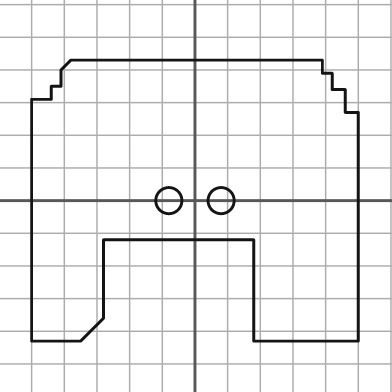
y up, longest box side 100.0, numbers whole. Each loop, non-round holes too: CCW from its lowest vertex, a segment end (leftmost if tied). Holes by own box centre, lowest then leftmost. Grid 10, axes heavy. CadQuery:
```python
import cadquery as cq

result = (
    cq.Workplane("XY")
    .moveTo(-50.0, -43.0)
    .lineTo(-35.0, -43.0)
    .lineTo(-28.0, -36.0)
    .lineTo(-28.0, -12.0)
    .lineTo(18.0, -12.0)
    .lineTo(18.0, -43.0)
    .lineTo(50.0, -43.0)
    .lineTo(50.0, 27.0)
    .lineTo(46.0, 27.0)
    .lineTo(46.0, 34.0)
    .lineTo(42.0, 34.0)
    .lineTo(42.0, 39.0)
    .lineTo(39.0, 39.0)
    .lineTo(39.0, 43.0)
    .lineTo(-38.0, 43.0)
    .lineTo(-41.0, 40.0)
    .lineTo(-41.0, 35.0)
    .lineTo(-44.0, 35.0)
    .lineTo(-44.0, 31.0)
    .lineTo(-50.0, 31.0)
    .close()
    .moveTo(-8.0, 0.0)
    .circle(4.0)
    .moveTo(8.0, 0.0)
    .circle(4.0)
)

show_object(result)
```